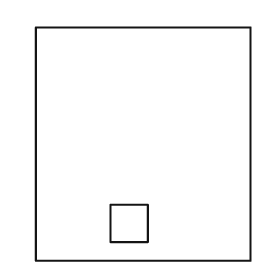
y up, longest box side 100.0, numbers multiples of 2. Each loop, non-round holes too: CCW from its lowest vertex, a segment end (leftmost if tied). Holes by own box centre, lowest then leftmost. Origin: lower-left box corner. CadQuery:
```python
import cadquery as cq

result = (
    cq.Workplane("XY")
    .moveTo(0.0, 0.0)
    .lineTo(92.0, 0.0)
    .lineTo(92.0, 100.0)
    .lineTo(0.0, 100.0)
    .close()
    .moveTo(32.0, 8.0)
    .lineTo(48.0, 8.0)
    .lineTo(48.0, 24.0)
    .lineTo(32.0, 24.0)
    .close()
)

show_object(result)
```